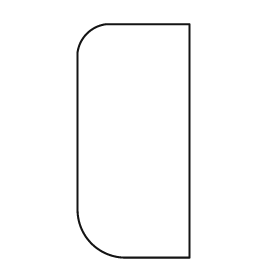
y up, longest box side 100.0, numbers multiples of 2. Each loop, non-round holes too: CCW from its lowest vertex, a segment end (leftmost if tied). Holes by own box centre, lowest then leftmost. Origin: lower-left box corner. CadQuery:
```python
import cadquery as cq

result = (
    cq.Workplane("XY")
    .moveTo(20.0, 0.0)
    .lineTo(48.0, 0.0)
    .lineTo(48.0, 100.0)
    .lineTo(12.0, 100.0)
    .threePointArc((4.0, 96.0), (0.0, 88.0))
    .lineTo(0.0, 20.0)
    .threePointArc((6.0, 6.0), (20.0, 0.0))
    .close()
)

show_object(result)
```